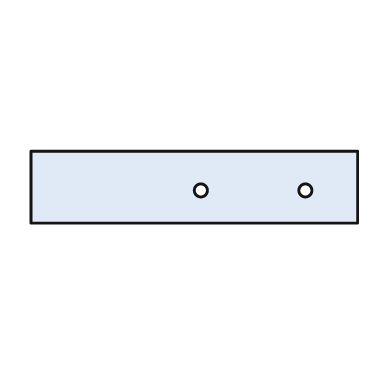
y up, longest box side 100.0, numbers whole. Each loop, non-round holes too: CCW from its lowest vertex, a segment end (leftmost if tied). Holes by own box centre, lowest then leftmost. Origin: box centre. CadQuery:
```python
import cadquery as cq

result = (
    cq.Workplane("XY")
    .moveTo(-50.0, -11.0)
    .lineTo(50.0, -11.0)
    .lineTo(50.0, 11.0)
    .lineTo(-50.0, 11.0)
    .close()
    .moveTo(2.0, -1.0)
    .circle(2.0)
    .moveTo(34.0, -1.0)
    .circle(2.0)
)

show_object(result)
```